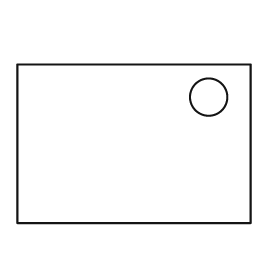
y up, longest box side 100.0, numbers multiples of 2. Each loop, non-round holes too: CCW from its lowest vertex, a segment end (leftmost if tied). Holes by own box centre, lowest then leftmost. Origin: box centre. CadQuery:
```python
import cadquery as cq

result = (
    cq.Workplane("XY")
    .moveTo(-50.0, -34.0)
    .lineTo(50.0, -34.0)
    .lineTo(50.0, 34.0)
    .lineTo(-50.0, 34.0)
    .close()
    .moveTo(32.0, 20.0)
    .circle(8.0)
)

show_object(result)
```